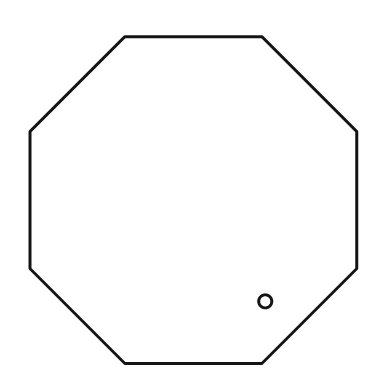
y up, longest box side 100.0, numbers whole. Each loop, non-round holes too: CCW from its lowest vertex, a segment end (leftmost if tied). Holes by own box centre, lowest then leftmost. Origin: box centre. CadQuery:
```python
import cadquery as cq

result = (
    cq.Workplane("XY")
    .moveTo(-21.0, -50.0)
    .lineTo(21.0, -50.0)
    .lineTo(50.0, -21.0)
    .lineTo(50.0, 21.0)
    .lineTo(21.0, 50.0)
    .lineTo(-21.0, 50.0)
    .lineTo(-50.0, 21.0)
    .lineTo(-50.0, -21.0)
    .close()
    .moveTo(22.0, -31.0)
    .circle(2.0)
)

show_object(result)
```